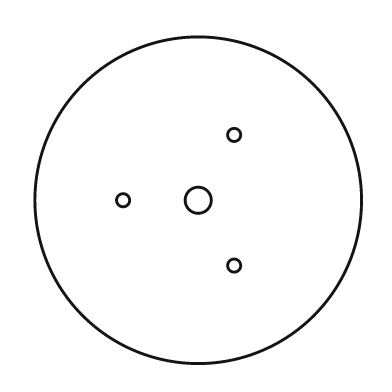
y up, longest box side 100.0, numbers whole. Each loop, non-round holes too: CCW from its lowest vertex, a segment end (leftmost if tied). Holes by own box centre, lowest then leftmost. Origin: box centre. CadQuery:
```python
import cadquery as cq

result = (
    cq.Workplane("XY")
    .moveTo(0.0, 0.0)
    .circle(50.0)
    .moveTo(11.0, -20.0)
    .circle(2.0)
    .moveTo(-23.0, 0.0)
    .circle(2.0)
    .moveTo(0.0, 0.0)
    .circle(4.0)
    .moveTo(11.0, 20.0)
    .circle(2.0)
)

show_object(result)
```